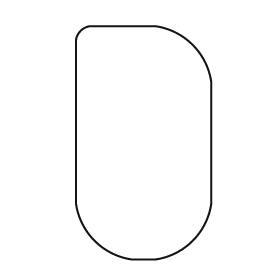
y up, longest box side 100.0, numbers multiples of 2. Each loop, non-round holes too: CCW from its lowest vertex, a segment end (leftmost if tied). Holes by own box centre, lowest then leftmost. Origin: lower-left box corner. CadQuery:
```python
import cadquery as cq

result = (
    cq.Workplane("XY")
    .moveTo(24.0, 0.0)
    .lineTo(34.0, 0.0)
    .threePointArc((50.0, 8.0), (58.0, 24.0))
    .lineTo(58.0, 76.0)
    .threePointArc((50.0, 92.0), (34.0, 100.0))
    .lineTo(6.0, 100.0)
    .threePointArc((2.0, 98.0), (0.0, 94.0))
    .lineTo(0.0, 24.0)
    .threePointArc((8.0, 8.0), (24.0, 0.0))
    .close()
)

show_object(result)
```